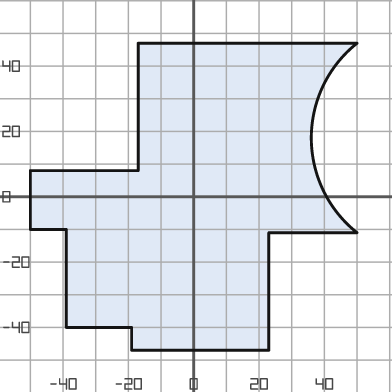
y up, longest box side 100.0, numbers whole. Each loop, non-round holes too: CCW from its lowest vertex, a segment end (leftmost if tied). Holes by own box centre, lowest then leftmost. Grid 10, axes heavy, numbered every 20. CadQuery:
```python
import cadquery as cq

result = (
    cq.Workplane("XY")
    .moveTo(-19.0, -47.0)
    .lineTo(23.0, -47.0)
    .lineTo(23.0, -11.0)
    .lineTo(50.0, -11.0)
    .threePointArc((36.0, 18.0), (50.0, 47.0))
    .lineTo(-17.0, 47.0)
    .lineTo(-17.0, 8.0)
    .lineTo(-50.0, 8.0)
    .lineTo(-50.0, -10.0)
    .lineTo(-39.0, -10.0)
    .lineTo(-39.0, -40.0)
    .lineTo(-19.0, -40.0)
    .close()
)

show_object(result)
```